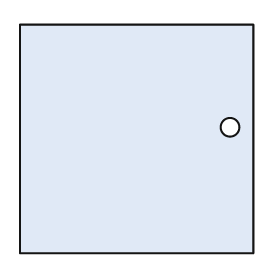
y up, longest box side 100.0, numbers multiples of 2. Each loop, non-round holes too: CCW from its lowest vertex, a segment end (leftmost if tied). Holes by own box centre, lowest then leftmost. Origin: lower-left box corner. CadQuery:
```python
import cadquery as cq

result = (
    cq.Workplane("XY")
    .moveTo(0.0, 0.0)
    .lineTo(100.0, 0.0)
    .lineTo(100.0, 98.0)
    .lineTo(0.0, 98.0)
    .close()
    .moveTo(90.0, 54.0)
    .circle(4.0)
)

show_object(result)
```